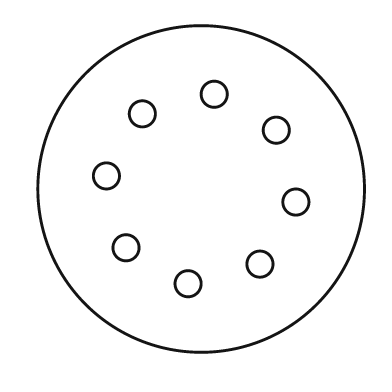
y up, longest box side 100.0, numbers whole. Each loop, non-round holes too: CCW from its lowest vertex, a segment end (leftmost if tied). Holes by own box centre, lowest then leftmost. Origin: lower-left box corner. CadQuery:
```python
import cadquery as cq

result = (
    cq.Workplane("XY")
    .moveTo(50.0, 50.0)
    .circle(50.0)
    .moveTo(46.0, 21.0)
    .circle(4.0)
    .moveTo(68.0, 27.0)
    .circle(4.0)
    .moveTo(27.0, 32.0)
    .circle(4.0)
    .moveTo(79.0, 46.0)
    .circle(4.0)
    .moveTo(21.0, 54.0)
    .circle(4.0)
    .moveTo(73.0, 68.0)
    .circle(4.0)
    .moveTo(32.0, 73.0)
    .circle(4.0)
    .moveTo(54.0, 79.0)
    .circle(4.0)
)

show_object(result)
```